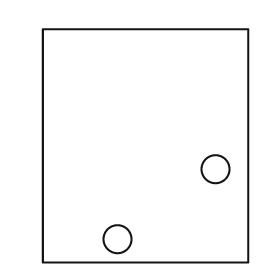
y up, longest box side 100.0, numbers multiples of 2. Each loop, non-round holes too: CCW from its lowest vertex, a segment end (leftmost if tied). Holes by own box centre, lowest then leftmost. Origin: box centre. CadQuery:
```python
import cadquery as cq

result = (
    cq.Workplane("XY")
    .moveTo(-44.0, -50.0)
    .lineTo(44.0, -50.0)
    .lineTo(44.0, 50.0)
    .lineTo(-44.0, 50.0)
    .close()
    .moveTo(-12.0, -40.0)
    .circle(6.0)
    .moveTo(30.0, -10.0)
    .circle(6.0)
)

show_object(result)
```